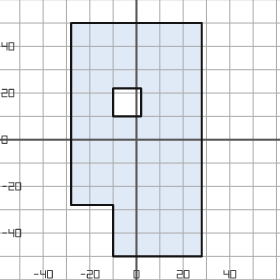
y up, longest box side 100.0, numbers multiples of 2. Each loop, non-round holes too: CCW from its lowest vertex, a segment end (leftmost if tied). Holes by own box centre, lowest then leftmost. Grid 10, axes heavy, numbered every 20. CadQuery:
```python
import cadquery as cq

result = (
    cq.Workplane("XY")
    .moveTo(-10.0, -50.0)
    .lineTo(28.0, -50.0)
    .lineTo(28.0, 50.0)
    .lineTo(-28.0, 50.0)
    .lineTo(-28.0, -28.0)
    .lineTo(-10.0, -28.0)
    .close()
    .moveTo(-10.0, 10.0)
    .lineTo(2.0, 10.0)
    .lineTo(2.0, 22.0)
    .lineTo(-10.0, 22.0)
    .close()
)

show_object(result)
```